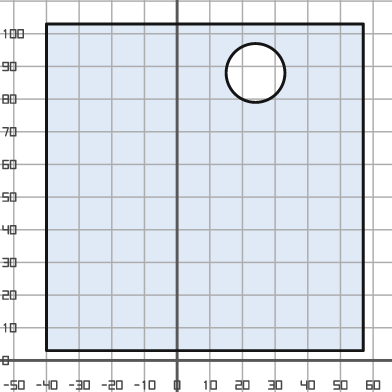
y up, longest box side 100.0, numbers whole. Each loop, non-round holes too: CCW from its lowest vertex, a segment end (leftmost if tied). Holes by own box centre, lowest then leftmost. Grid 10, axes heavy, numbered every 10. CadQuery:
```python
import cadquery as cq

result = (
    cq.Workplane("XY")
    .moveTo(-40.0, 3.0)
    .lineTo(57.0, 3.0)
    .lineTo(57.0, 103.0)
    .lineTo(-40.0, 103.0)
    .close()
    .moveTo(24.0, 88.0)
    .circle(9.0)
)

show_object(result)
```